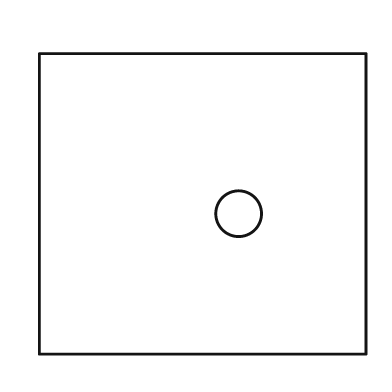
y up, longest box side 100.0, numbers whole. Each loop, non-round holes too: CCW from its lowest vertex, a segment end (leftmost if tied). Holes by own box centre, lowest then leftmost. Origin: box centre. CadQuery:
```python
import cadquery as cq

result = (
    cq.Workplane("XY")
    .moveTo(-50.0, -46.0)
    .lineTo(50.0, -46.0)
    .lineTo(50.0, 46.0)
    .lineTo(-50.0, 46.0)
    .close()
    .moveTo(11.0, -3.0)
    .circle(7.0)
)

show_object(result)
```